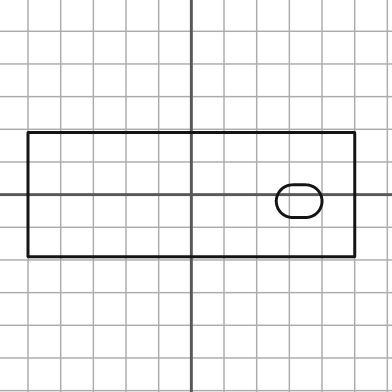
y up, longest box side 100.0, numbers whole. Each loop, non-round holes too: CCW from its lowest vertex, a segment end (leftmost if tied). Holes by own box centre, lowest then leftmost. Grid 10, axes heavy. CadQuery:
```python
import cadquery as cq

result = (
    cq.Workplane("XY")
    .moveTo(-50.0, -19.0)
    .lineTo(50.0, -19.0)
    .lineTo(50.0, 19.0)
    .lineTo(-50.0, 19.0)
    .close()
    .moveTo(31.0, -7.0)
    .lineTo(35.0, -7.0)
    .threePointArc((40.0, -2.0), (35.0, 3.0))
    .lineTo(31.0, 3.0)
    .threePointArc((26.0, -2.0), (31.0, -7.0))
    .close()
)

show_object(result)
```